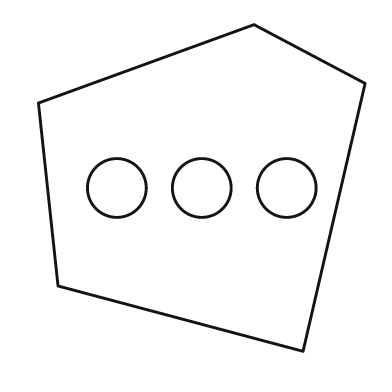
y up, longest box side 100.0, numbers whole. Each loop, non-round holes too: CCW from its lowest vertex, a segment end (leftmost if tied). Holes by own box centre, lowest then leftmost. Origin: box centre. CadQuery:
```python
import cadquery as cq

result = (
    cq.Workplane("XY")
    .moveTo(31.0, -50.0)
    .lineTo(50.0, 32.0)
    .lineTo(16.0, 50.0)
    .lineTo(-50.0, 26.0)
    .lineTo(-44.0, -30.0)
    .close()
    .moveTo(-26.0, 0.0)
    .circle(9.0)
    .moveTo(0.0, 0.0)
    .circle(9.0)
    .moveTo(26.0, 0.0)
    .circle(9.0)
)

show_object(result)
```